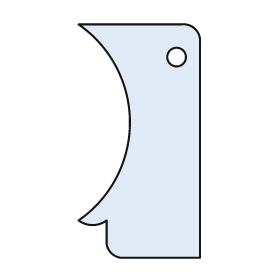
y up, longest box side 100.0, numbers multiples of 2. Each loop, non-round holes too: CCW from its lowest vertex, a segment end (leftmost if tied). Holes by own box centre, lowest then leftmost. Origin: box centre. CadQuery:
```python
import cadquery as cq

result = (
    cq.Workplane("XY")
    .moveTo(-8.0, -50.0)
    .lineTo(26.0, -50.0)
    .lineTo(26.0, 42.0)
    .threePointArc((24.0, 48.0), (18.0, 50.0))
    .lineTo(-26.0, 50.0)
    .threePointArc((-4.0, 8.0), (-26.0, -34.0))
    .threePointArc((-20.0, -36.0), (-14.0, -34.0))
    .lineTo(-14.0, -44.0)
    .threePointArc((-12.0, -48.0), (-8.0, -50.0))
    .close()
    .moveTo(16.0, 36.0)
    .circle(4.0)
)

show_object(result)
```